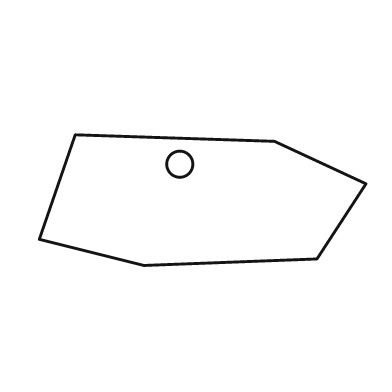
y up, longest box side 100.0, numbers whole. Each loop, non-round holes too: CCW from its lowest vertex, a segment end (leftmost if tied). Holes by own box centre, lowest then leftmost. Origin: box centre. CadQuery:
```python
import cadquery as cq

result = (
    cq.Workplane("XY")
    .moveTo(-18.0, -20.0)
    .lineTo(35.0, -18.0)
    .lineTo(50.0, 5.0)
    .lineTo(22.0, 18.0)
    .lineTo(-39.0, 20.0)
    .lineTo(-50.0, -12.0)
    .close()
    .moveTo(-7.0, 11.0)
    .circle(4.0)
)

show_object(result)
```